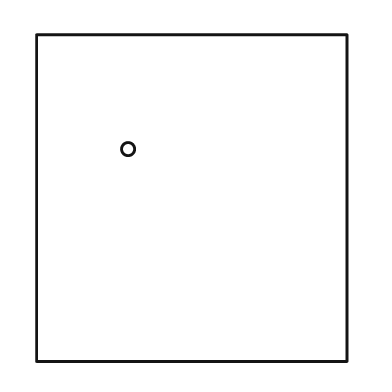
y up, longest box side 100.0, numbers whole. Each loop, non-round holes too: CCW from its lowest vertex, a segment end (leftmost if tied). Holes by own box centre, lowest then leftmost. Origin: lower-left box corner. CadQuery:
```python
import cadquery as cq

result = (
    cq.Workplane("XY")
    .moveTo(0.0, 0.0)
    .lineTo(95.0, 0.0)
    .lineTo(95.0, 100.0)
    .lineTo(0.0, 100.0)
    .close()
    .moveTo(28.0, 65.0)
    .circle(2.0)
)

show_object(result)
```